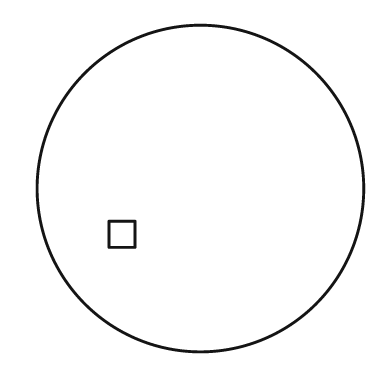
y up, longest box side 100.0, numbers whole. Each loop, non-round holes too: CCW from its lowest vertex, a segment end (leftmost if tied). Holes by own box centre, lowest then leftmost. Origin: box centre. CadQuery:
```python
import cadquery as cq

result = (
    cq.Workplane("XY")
    .moveTo(0.0, 0.0)
    .circle(50.0)
    .moveTo(-28.0, -18.0)
    .lineTo(-20.0, -18.0)
    .lineTo(-20.0, -10.0)
    .lineTo(-28.0, -10.0)
    .close()
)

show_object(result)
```